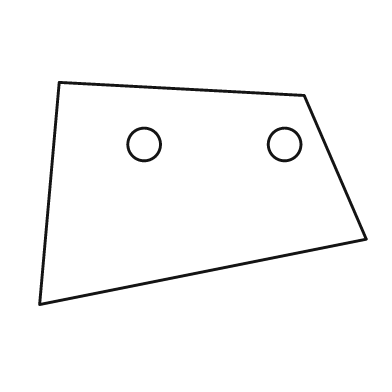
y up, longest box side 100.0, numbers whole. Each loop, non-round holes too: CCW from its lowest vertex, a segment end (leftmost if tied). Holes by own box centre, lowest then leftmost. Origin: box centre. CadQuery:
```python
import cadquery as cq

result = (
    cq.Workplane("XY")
    .moveTo(-50.0, -34.0)
    .lineTo(50.0, -14.0)
    .lineTo(31.0, 30.0)
    .lineTo(-44.0, 34.0)
    .close()
    .moveTo(-18.0, 15.0)
    .circle(5.0)
    .moveTo(25.0, 15.0)
    .circle(5.0)
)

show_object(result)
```